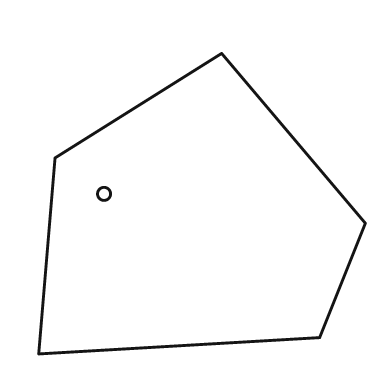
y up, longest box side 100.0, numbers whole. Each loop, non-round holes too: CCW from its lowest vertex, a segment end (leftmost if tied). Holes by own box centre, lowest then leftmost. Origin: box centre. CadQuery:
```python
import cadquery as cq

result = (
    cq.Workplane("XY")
    .moveTo(-50.0, -46.0)
    .lineTo(36.0, -41.0)
    .lineTo(50.0, -6.0)
    .lineTo(6.0, 46.0)
    .lineTo(-45.0, 14.0)
    .close()
    .moveTo(-30.0, 3.0)
    .circle(2.0)
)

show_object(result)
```